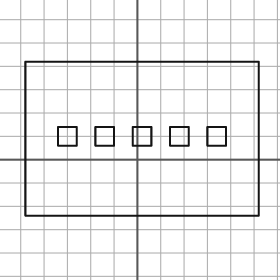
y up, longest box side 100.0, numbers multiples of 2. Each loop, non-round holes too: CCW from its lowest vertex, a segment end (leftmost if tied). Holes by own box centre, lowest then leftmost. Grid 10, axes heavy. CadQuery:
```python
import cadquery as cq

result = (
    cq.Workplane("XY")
    .moveTo(-48.0, -24.0)
    .lineTo(52.0, -24.0)
    .lineTo(52.0, 42.0)
    .lineTo(-48.0, 42.0)
    .close()
    .moveTo(-34.0, 6.0)
    .lineTo(-26.0, 6.0)
    .lineTo(-26.0, 14.0)
    .lineTo(-34.0, 14.0)
    .close()
    .moveTo(-18.0, 6.0)
    .lineTo(-10.0, 6.0)
    .lineTo(-10.0, 14.0)
    .lineTo(-18.0, 14.0)
    .close()
    .moveTo(-2.0, 6.0)
    .lineTo(6.0, 6.0)
    .lineTo(6.0, 14.0)
    .lineTo(-2.0, 14.0)
    .close()
    .moveTo(14.0, 6.0)
    .lineTo(22.0, 6.0)
    .lineTo(22.0, 14.0)
    .lineTo(14.0, 14.0)
    .close()
    .moveTo(30.0, 6.0)
    .lineTo(38.0, 6.0)
    .lineTo(38.0, 14.0)
    .lineTo(30.0, 14.0)
    .close()
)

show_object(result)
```